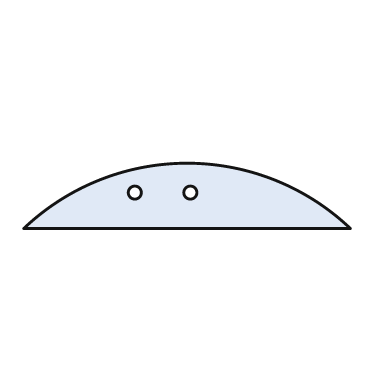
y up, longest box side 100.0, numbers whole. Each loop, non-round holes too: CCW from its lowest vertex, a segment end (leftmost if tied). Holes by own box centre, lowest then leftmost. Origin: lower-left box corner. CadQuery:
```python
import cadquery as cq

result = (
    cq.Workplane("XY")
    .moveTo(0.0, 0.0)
    .lineTo(100.0, 0.0)
    .threePointArc((50.0, 20.0), (0.0, 0.0))
    .close()
    .moveTo(34.0, 11.0)
    .circle(2.0)
    .moveTo(51.0, 11.0)
    .circle(2.0)
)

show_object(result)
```